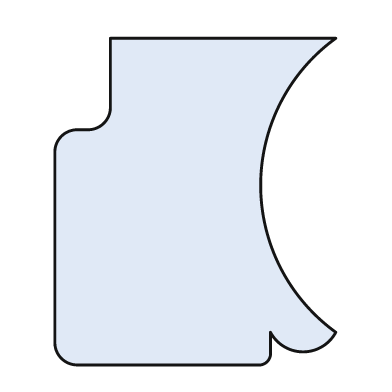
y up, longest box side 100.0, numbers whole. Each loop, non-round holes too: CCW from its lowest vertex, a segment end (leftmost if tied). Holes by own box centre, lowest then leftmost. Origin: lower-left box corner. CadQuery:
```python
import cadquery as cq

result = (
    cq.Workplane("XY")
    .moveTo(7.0, 0.0)
    .lineTo(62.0, 0.0)
    .threePointArc((65.0, 1.0), (66.0, 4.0))
    .lineTo(66.0, 10.0)
    .threePointArc((76.0, 4.0), (86.0, 10.0))
    .threePointArc((63.0, 55.0), (86.0, 100.0))
    .lineTo(17.0, 100.0)
    .lineTo(17.0, 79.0)
    .threePointArc((15.0, 74.0), (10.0, 72.0))
    .lineTo(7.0, 72.0)
    .threePointArc((2.0, 70.0), (0.0, 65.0))
    .lineTo(0.0, 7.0)
    .threePointArc((2.0, 2.0), (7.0, 0.0))
    .close()
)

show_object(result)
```